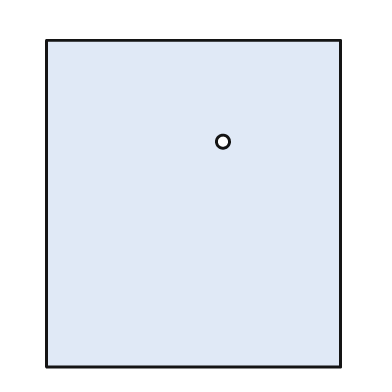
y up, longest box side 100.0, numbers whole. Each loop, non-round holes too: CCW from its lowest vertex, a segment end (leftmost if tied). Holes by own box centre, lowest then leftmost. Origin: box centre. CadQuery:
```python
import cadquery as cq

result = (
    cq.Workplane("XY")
    .moveTo(-45.0, -50.0)
    .lineTo(45.0, -50.0)
    .lineTo(45.0, 50.0)
    .lineTo(-45.0, 50.0)
    .close()
    .moveTo(9.0, 19.0)
    .circle(2.0)
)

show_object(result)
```